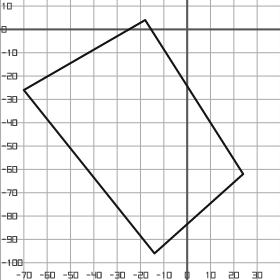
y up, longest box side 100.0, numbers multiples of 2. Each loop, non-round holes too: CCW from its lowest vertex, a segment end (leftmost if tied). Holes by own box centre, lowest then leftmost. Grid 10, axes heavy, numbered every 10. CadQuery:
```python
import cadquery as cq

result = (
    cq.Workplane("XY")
    .moveTo(-14.0, -96.0)
    .lineTo(24.0, -62.0)
    .lineTo(-18.0, 4.0)
    .lineTo(-70.0, -26.0)
    .close()
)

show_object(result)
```